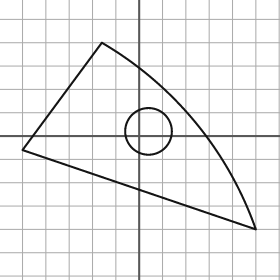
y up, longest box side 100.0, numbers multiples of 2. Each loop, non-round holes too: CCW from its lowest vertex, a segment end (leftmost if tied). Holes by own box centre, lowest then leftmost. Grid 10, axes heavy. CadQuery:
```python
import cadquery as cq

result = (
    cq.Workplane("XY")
    .moveTo(50.0, -40.0)
    .threePointArc((24.0, 6.0), (-16.0, 40.0))
    .lineTo(-50.0, -6.0)
    .close()
    .moveTo(4.0, 2.0)
    .circle(10.0)
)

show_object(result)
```